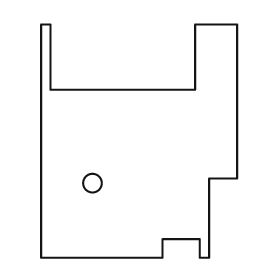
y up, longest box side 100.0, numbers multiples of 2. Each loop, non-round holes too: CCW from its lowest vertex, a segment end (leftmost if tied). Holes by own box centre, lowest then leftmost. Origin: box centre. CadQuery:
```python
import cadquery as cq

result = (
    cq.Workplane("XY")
    .moveTo(-42.0, -50.0)
    .lineTo(10.0, -50.0)
    .lineTo(10.0, -42.0)
    .lineTo(26.0, -42.0)
    .lineTo(26.0, -50.0)
    .lineTo(30.0, -50.0)
    .lineTo(30.0, -16.0)
    .lineTo(42.0, -16.0)
    .lineTo(42.0, 50.0)
    .lineTo(24.0, 50.0)
    .lineTo(24.0, 22.0)
    .lineTo(-38.0, 22.0)
    .lineTo(-38.0, 50.0)
    .lineTo(-42.0, 50.0)
    .close()
    .moveTo(-20.0, -18.0)
    .circle(4.0)
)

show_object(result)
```